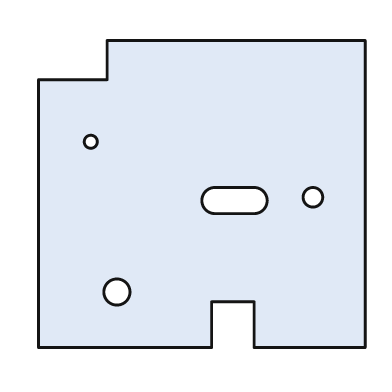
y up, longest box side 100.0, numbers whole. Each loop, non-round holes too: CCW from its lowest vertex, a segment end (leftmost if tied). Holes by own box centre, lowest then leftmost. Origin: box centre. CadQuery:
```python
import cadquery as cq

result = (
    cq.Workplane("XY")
    .moveTo(-50.0, -47.0)
    .lineTo(3.0, -47.0)
    .lineTo(3.0, -33.0)
    .lineTo(16.0, -33.0)
    .lineTo(16.0, -47.0)
    .lineTo(50.0, -47.0)
    .lineTo(50.0, 47.0)
    .lineTo(-29.0, 47.0)
    .lineTo(-29.0, 35.0)
    .lineTo(-50.0, 35.0)
    .close()
    .moveTo(-26.0, -30.0)
    .circle(4.0)
    .moveTo(4.0, -6.0)
    .lineTo(16.0, -6.0)
    .threePointArc((20.0, -2.0), (16.0, 2.0))
    .lineTo(4.0, 2.0)
    .threePointArc((0.0, -2.0), (4.0, -6.0))
    .close()
    .moveTo(34.0, -1.0)
    .circle(3.0)
    .moveTo(-34.0, 16.0)
    .circle(2.0)
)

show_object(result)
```